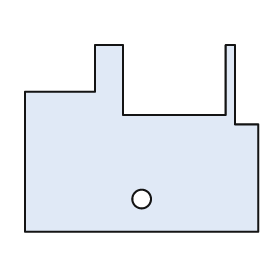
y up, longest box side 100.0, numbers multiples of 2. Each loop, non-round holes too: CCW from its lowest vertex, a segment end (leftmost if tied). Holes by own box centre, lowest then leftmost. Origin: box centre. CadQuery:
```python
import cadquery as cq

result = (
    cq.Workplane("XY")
    .moveTo(-50.0, -40.0)
    .lineTo(50.0, -40.0)
    .lineTo(50.0, 6.0)
    .lineTo(40.0, 6.0)
    .lineTo(40.0, 40.0)
    .lineTo(36.0, 40.0)
    .lineTo(36.0, 10.0)
    .lineTo(-8.0, 10.0)
    .lineTo(-8.0, 40.0)
    .lineTo(-20.0, 40.0)
    .lineTo(-20.0, 20.0)
    .lineTo(-50.0, 20.0)
    .close()
    .moveTo(0.0, -26.0)
    .circle(4.0)
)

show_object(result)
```